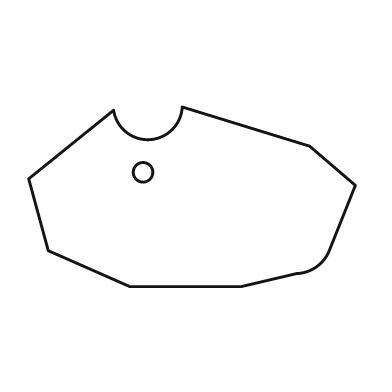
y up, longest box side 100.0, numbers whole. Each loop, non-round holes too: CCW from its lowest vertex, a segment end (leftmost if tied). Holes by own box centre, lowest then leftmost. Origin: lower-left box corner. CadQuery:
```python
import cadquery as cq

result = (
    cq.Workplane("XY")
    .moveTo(31.0, 0.0)
    .lineTo(65.0, 0.0)
    .lineTo(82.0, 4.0)
    .threePointArc((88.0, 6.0), (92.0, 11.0))
    .lineTo(100.0, 31.0)
    .lineTo(86.0, 43.0)
    .lineTo(47.0, 55.0)
    .threePointArc((37.0, 45.0), (26.0, 54.0))
    .lineTo(0.0, 33.0)
    .lineTo(6.0, 11.0)
    .close()
    .moveTo(35.0, 35.0)
    .circle(3.0)
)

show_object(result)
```